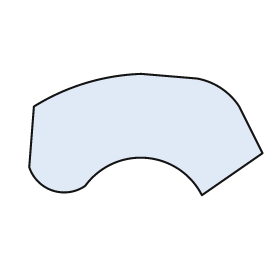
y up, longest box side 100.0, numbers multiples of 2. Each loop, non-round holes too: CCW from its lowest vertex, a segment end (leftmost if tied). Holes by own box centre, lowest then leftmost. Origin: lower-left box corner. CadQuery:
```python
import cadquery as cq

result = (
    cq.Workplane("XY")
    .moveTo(74.0, 0.0)
    .lineTo(100.0, 18.0)
    .lineTo(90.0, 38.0)
    .threePointArc((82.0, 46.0), (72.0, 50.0))
    .lineTo(48.0, 52.0)
    .threePointArc((24.0, 48.0), (2.0, 38.0))
    .lineTo(0.0, 12.0)
    .threePointArc((10.0, 2.0), (24.0, 4.0))
    .threePointArc((50.0, 16.0), (74.0, 0.0))
    .close()
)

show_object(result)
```